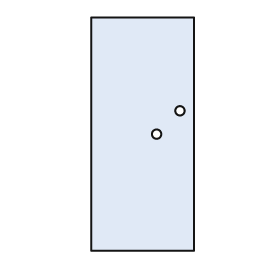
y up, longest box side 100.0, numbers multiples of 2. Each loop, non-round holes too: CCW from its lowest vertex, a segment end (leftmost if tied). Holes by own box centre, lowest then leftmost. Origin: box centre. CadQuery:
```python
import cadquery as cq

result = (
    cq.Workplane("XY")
    .moveTo(-22.0, -50.0)
    .lineTo(22.0, -50.0)
    .lineTo(22.0, 50.0)
    .lineTo(-22.0, 50.0)
    .close()
    .moveTo(6.0, 0.0)
    .circle(2.0)
    .moveTo(16.0, 10.0)
    .circle(2.0)
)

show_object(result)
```